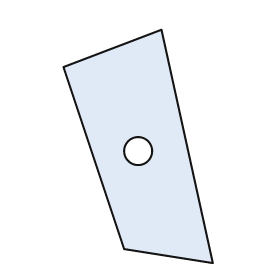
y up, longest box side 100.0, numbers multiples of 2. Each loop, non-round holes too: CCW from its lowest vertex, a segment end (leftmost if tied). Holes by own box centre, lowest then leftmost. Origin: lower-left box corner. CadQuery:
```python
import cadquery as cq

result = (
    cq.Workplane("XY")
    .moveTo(64.0, 0.0)
    .lineTo(42.0, 100.0)
    .lineTo(0.0, 84.0)
    .lineTo(26.0, 6.0)
    .close()
    .moveTo(32.0, 48.0)
    .circle(6.0)
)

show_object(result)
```